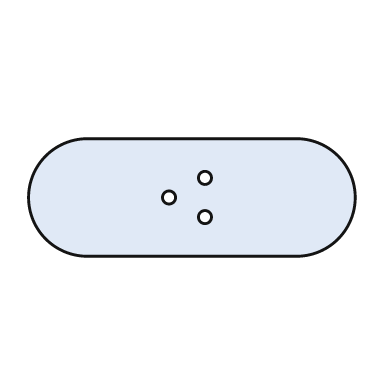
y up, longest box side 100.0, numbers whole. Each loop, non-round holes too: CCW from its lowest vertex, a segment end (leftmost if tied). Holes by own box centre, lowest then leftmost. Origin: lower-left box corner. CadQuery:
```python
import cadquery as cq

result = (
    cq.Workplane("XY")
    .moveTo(18.0, 0.0)
    .lineTo(82.0, 0.0)
    .threePointArc((100.0, 18.0), (82.0, 36.0))
    .lineTo(18.0, 36.0)
    .threePointArc((0.0, 18.0), (18.0, 0.0))
    .close()
    .moveTo(54.0, 12.0)
    .circle(2.0)
    .moveTo(43.0, 18.0)
    .circle(2.0)
    .moveTo(54.0, 24.0)
    .circle(2.0)
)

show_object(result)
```